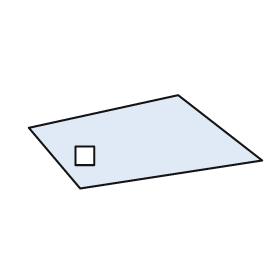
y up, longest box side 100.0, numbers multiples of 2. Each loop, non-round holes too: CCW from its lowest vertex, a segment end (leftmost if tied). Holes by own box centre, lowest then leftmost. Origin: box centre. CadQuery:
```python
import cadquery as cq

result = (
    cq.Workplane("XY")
    .moveTo(-28.0, -20.0)
    .lineTo(50.0, -8.0)
    .lineTo(14.0, 20.0)
    .lineTo(-50.0, 6.0)
    .close()
    .moveTo(-30.0, -10.0)
    .lineTo(-22.0, -10.0)
    .lineTo(-22.0, -2.0)
    .lineTo(-30.0, -2.0)
    .close()
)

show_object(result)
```